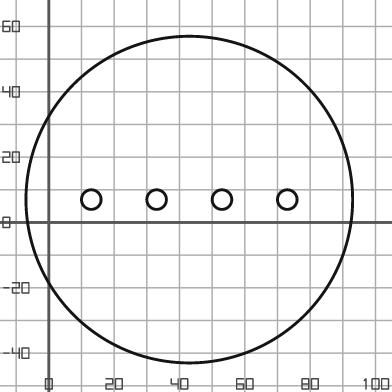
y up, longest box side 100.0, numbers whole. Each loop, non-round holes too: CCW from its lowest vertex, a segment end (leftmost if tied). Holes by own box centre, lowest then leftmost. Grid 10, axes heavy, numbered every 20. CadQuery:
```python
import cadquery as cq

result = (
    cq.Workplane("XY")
    .moveTo(43.0, 7.0)
    .circle(50.0)
    .moveTo(13.0, 7.0)
    .circle(3.0)
    .moveTo(33.0, 7.0)
    .circle(3.0)
    .moveTo(53.0, 7.0)
    .circle(3.0)
    .moveTo(73.0, 7.0)
    .circle(3.0)
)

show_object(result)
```